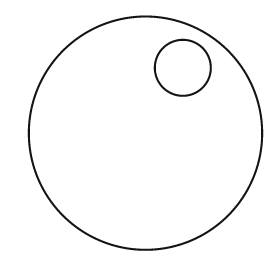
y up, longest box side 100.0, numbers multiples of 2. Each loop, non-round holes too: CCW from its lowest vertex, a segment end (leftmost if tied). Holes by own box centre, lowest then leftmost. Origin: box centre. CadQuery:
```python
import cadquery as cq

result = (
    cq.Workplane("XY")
    .moveTo(0.0, 0.0)
    .circle(50.0)
    .moveTo(16.0, 28.0)
    .circle(12.0)
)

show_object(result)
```